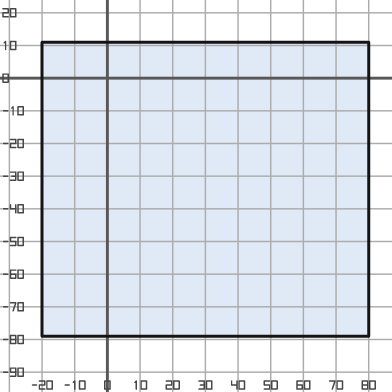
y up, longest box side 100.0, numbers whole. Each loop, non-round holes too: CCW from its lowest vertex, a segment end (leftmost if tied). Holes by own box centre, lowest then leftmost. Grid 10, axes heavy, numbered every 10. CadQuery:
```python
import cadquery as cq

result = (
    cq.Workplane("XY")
    .moveTo(-20.0, -79.0)
    .lineTo(80.0, -79.0)
    .lineTo(80.0, 11.0)
    .lineTo(-20.0, 11.0)
    .close()
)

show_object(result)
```